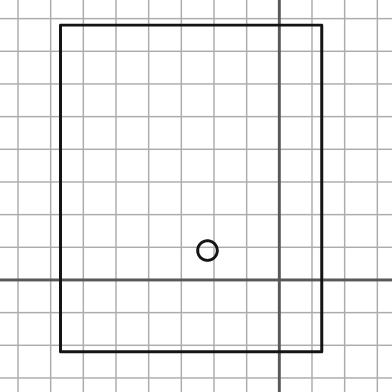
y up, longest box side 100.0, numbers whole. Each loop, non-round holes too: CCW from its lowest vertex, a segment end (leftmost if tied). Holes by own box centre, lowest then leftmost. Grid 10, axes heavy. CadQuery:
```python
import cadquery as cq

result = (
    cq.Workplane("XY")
    .moveTo(-67.0, -22.0)
    .lineTo(13.0, -22.0)
    .lineTo(13.0, 78.0)
    .lineTo(-67.0, 78.0)
    .close()
    .moveTo(-22.0, 9.0)
    .circle(3.0)
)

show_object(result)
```